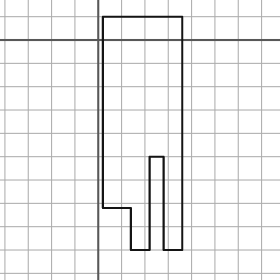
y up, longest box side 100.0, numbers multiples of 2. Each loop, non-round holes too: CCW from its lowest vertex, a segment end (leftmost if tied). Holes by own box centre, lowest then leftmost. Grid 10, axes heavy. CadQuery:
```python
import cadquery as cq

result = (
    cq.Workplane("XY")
    .moveTo(14.0, -90.0)
    .lineTo(22.0, -90.0)
    .lineTo(22.0, -50.0)
    .lineTo(28.0, -50.0)
    .lineTo(28.0, -90.0)
    .lineTo(36.0, -90.0)
    .lineTo(36.0, 10.0)
    .lineTo(2.0, 10.0)
    .lineTo(2.0, -72.0)
    .lineTo(14.0, -72.0)
    .close()
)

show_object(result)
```